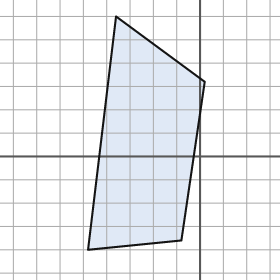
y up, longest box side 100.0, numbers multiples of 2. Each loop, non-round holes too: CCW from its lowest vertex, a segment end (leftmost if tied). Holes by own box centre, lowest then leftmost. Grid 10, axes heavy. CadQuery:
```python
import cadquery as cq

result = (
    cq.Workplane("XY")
    .moveTo(-48.0, -40.0)
    .lineTo(-8.0, -36.0)
    .lineTo(2.0, 32.0)
    .lineTo(-36.0, 60.0)
    .close()
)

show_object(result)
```